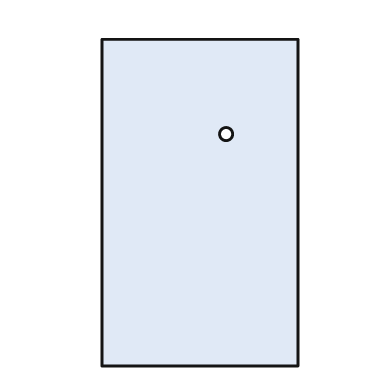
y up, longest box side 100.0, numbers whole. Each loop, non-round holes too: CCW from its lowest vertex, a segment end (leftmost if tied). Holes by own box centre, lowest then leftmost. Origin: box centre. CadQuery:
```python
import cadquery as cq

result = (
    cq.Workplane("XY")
    .moveTo(-30.0, -50.0)
    .lineTo(30.0, -50.0)
    .lineTo(30.0, 50.0)
    .lineTo(-30.0, 50.0)
    .close()
    .moveTo(8.0, 21.0)
    .circle(2.0)
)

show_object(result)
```